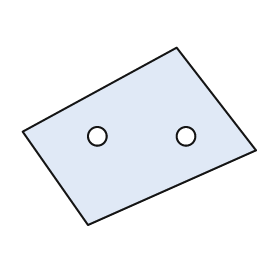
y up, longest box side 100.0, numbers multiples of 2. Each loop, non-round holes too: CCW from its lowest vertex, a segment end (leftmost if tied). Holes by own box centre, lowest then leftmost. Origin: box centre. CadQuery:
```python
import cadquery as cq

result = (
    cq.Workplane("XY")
    .moveTo(-22.0, -38.0)
    .lineTo(50.0, -6.0)
    .lineTo(16.0, 38.0)
    .lineTo(-50.0, 2.0)
    .close()
    .moveTo(-18.0, 0.0)
    .circle(4.0)
    .moveTo(20.0, 0.0)
    .circle(4.0)
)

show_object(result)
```